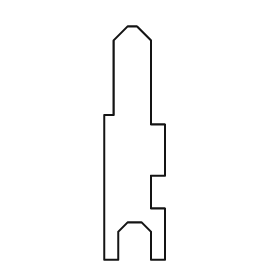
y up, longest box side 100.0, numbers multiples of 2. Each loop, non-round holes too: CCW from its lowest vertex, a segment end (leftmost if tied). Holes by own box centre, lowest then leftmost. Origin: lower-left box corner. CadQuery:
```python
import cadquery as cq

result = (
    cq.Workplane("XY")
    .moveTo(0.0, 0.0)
    .lineTo(6.0, 0.0)
    .lineTo(6.0, 12.0)
    .lineTo(10.0, 16.0)
    .lineTo(16.0, 16.0)
    .lineTo(20.0, 12.0)
    .lineTo(20.0, 0.0)
    .lineTo(26.0, 0.0)
    .lineTo(26.0, 22.0)
    .lineTo(20.0, 22.0)
    .lineTo(20.0, 36.0)
    .lineTo(26.0, 36.0)
    .lineTo(26.0, 58.0)
    .lineTo(20.0, 58.0)
    .lineTo(20.0, 94.0)
    .lineTo(14.0, 100.0)
    .lineTo(10.0, 100.0)
    .lineTo(4.0, 94.0)
    .lineTo(4.0, 62.0)
    .lineTo(0.0, 62.0)
    .close()
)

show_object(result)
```